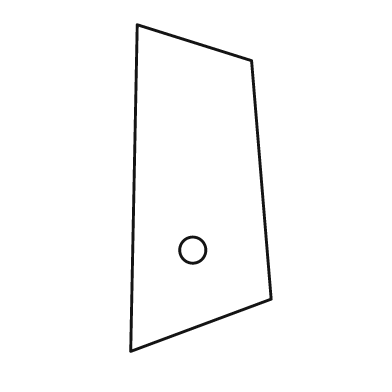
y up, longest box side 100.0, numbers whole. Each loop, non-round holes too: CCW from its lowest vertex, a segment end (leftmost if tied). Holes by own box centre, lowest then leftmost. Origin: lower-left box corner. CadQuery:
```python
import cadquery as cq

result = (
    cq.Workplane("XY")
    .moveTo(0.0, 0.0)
    .lineTo(43.0, 16.0)
    .lineTo(37.0, 89.0)
    .lineTo(2.0, 100.0)
    .close()
    .moveTo(19.0, 31.0)
    .circle(4.0)
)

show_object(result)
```